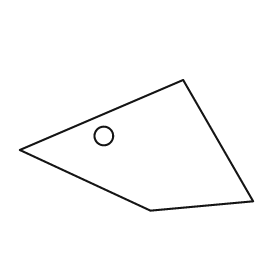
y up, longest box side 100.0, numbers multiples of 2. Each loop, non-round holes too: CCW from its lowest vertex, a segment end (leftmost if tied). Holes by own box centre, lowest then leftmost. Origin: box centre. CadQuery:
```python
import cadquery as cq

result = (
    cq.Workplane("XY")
    .moveTo(6.0, -28.0)
    .lineTo(50.0, -24.0)
    .lineTo(20.0, 28.0)
    .lineTo(-50.0, -2.0)
    .close()
    .moveTo(-14.0, 4.0)
    .circle(4.0)
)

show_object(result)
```